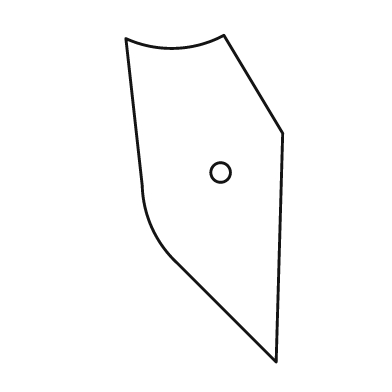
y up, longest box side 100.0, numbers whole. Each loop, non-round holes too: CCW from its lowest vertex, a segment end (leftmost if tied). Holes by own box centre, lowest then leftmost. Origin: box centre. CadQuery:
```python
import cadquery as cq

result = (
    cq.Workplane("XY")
    .moveTo(22.0, -50.0)
    .lineTo(24.0, 20.0)
    .lineTo(6.0, 50.0)
    .threePointArc((-9.0, 46.0), (-24.0, 49.0))
    .lineTo(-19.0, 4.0)
    .threePointArc((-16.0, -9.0), (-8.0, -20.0))
    .close()
    .moveTo(5.0, 8.0)
    .circle(3.0)
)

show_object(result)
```